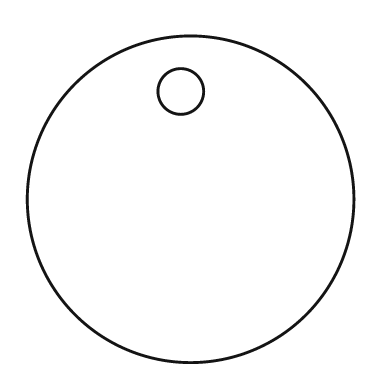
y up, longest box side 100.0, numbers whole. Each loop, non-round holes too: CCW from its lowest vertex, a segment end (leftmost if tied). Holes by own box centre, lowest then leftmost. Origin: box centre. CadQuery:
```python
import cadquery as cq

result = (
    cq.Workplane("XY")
    .moveTo(0.0, 0.0)
    .circle(50.0)
    .moveTo(-3.0, 33.0)
    .circle(7.0)
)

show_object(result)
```